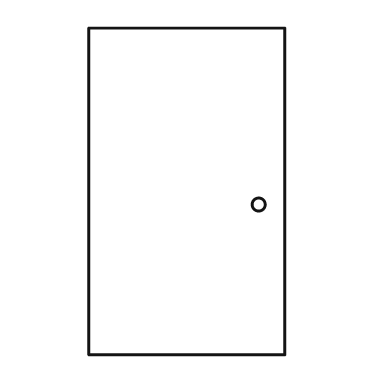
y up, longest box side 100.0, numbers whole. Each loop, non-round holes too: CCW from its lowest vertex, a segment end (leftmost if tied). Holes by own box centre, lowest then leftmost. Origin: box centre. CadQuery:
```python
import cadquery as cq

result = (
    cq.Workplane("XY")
    .moveTo(-30.0, -50.0)
    .lineTo(30.0, -50.0)
    .lineTo(30.0, 50.0)
    .lineTo(-30.0, 50.0)
    .close()
    .moveTo(22.0, -4.0)
    .circle(2.0)
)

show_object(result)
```